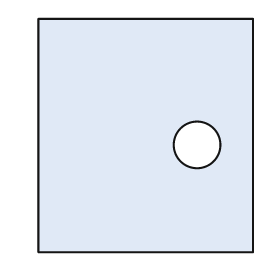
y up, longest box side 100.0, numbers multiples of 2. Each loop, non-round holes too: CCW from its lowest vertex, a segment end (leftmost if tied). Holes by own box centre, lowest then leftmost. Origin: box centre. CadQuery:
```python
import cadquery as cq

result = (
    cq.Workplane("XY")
    .moveTo(-46.0, -50.0)
    .lineTo(46.0, -50.0)
    .lineTo(46.0, 50.0)
    .lineTo(-46.0, 50.0)
    .close()
    .moveTo(22.0, -4.0)
    .circle(10.0)
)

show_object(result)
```